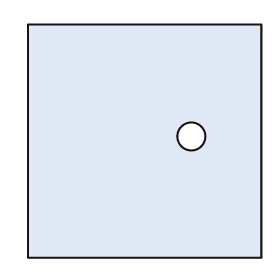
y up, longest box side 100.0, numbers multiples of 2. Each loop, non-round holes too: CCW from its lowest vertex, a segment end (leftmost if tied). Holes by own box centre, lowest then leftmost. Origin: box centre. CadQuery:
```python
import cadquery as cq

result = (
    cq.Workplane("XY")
    .moveTo(-50.0, -50.0)
    .lineTo(50.0, -50.0)
    .lineTo(50.0, 50.0)
    .lineTo(-50.0, 50.0)
    .close()
    .moveTo(20.0, 2.0)
    .circle(6.0)
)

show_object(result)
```